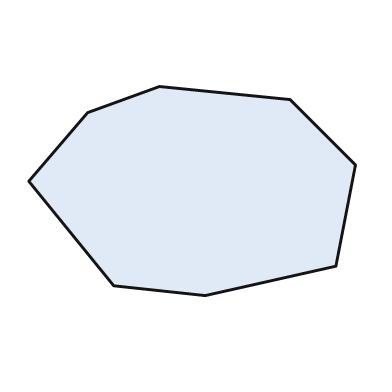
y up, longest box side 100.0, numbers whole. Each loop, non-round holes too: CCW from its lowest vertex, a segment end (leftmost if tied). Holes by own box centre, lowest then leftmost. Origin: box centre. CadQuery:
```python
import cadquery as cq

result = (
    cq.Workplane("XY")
    .moveTo(4.0, -32.0)
    .lineTo(44.0, -23.0)
    .lineTo(50.0, 8.0)
    .lineTo(30.0, 28.0)
    .lineTo(-10.0, 32.0)
    .lineTo(-32.0, 24.0)
    .lineTo(-50.0, 3.0)
    .lineTo(-24.0, -29.0)
    .close()
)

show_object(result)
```